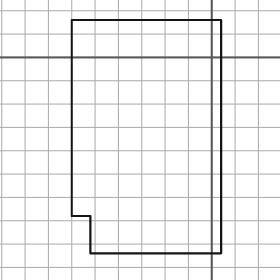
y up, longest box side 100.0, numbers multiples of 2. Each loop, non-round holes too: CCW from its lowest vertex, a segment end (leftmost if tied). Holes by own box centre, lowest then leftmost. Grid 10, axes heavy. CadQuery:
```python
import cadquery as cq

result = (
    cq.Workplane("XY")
    .moveTo(-52.0, -84.0)
    .lineTo(4.0, -84.0)
    .lineTo(4.0, 16.0)
    .lineTo(-60.0, 16.0)
    .lineTo(-60.0, -68.0)
    .lineTo(-52.0, -68.0)
    .close()
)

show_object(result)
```